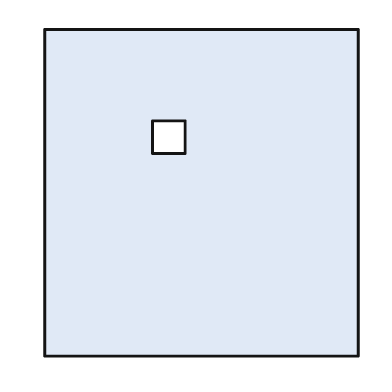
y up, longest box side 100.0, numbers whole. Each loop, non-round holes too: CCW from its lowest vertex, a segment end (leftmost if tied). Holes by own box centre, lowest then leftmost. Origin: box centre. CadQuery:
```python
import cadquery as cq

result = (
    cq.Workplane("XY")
    .moveTo(-48.0, -50.0)
    .lineTo(48.0, -50.0)
    .lineTo(48.0, 50.0)
    .lineTo(-48.0, 50.0)
    .close()
    .moveTo(-15.0, 12.0)
    .lineTo(-5.0, 12.0)
    .lineTo(-5.0, 22.0)
    .lineTo(-15.0, 22.0)
    .close()
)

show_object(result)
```